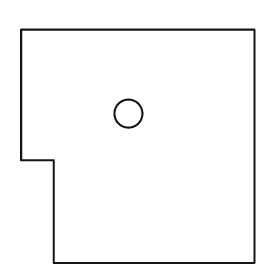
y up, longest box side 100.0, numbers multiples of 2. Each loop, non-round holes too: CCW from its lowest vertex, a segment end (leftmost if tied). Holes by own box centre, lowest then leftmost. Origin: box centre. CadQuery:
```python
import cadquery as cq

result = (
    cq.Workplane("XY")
    .moveTo(-36.0, -50.0)
    .lineTo(50.0, -50.0)
    .lineTo(50.0, 50.0)
    .lineTo(-50.0, 50.0)
    .lineTo(-50.0, -6.0)
    .lineTo(-36.0, -6.0)
    .close()
    .moveTo(-4.0, 14.0)
    .circle(6.0)
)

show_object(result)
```